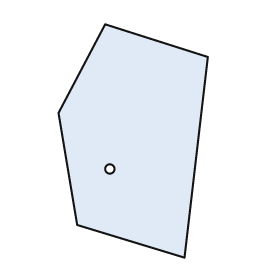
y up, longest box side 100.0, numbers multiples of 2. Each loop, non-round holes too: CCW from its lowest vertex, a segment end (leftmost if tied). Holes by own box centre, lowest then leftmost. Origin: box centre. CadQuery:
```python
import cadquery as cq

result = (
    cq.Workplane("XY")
    .moveTo(22.0, -50.0)
    .lineTo(32.0, 36.0)
    .lineTo(-12.0, 50.0)
    .lineTo(-32.0, 12.0)
    .lineTo(-24.0, -36.0)
    .close()
    .moveTo(-10.0, -12.0)
    .circle(2.0)
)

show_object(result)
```